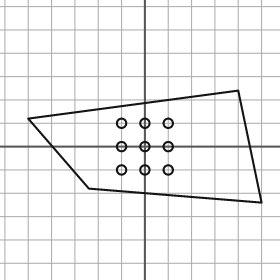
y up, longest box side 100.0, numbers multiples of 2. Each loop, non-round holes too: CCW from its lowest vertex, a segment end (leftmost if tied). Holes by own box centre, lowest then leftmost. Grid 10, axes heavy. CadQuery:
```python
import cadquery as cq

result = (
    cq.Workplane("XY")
    .moveTo(50.0, -24.0)
    .lineTo(40.0, 24.0)
    .lineTo(-50.0, 12.0)
    .lineTo(-24.0, -18.0)
    .close()
    .moveTo(-10.0, -10.0)
    .circle(2.0)
    .moveTo(0.0, -10.0)
    .circle(2.0)
    .moveTo(10.0, -10.0)
    .circle(2.0)
    .moveTo(-10.0, 0.0)
    .circle(2.0)
    .moveTo(0.0, 0.0)
    .circle(2.0)
    .moveTo(10.0, 0.0)
    .circle(2.0)
    .moveTo(-10.0, 10.0)
    .circle(2.0)
    .moveTo(0.0, 10.0)
    .circle(2.0)
    .moveTo(10.0, 10.0)
    .circle(2.0)
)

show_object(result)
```